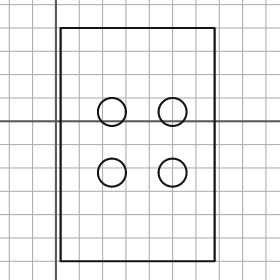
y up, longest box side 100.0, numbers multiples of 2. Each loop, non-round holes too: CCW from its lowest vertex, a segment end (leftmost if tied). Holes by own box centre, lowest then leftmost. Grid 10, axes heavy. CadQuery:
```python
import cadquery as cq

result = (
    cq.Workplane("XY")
    .moveTo(2.0, -60.0)
    .lineTo(68.0, -60.0)
    .lineTo(68.0, 40.0)
    .lineTo(2.0, 40.0)
    .close()
    .moveTo(24.0, -22.0)
    .circle(6.0)
    .moveTo(50.0, -22.0)
    .circle(6.0)
    .moveTo(24.0, 4.0)
    .circle(6.0)
    .moveTo(50.0, 4.0)
    .circle(6.0)
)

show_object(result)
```